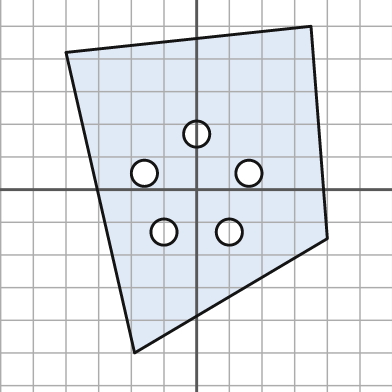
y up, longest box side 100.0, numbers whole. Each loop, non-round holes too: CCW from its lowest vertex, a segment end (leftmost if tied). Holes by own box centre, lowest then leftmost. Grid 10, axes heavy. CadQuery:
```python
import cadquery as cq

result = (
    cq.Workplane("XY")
    .moveTo(-19.0, -50.0)
    .lineTo(40.0, -15.0)
    .lineTo(35.0, 50.0)
    .lineTo(-40.0, 42.0)
    .close()
    .moveTo(-10.0, -13.0)
    .circle(4.0)
    .moveTo(10.0, -13.0)
    .circle(4.0)
    .moveTo(-16.0, 5.0)
    .circle(4.0)
    .moveTo(16.0, 5.0)
    .circle(4.0)
    .moveTo(0.0, 17.0)
    .circle(4.0)
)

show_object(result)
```